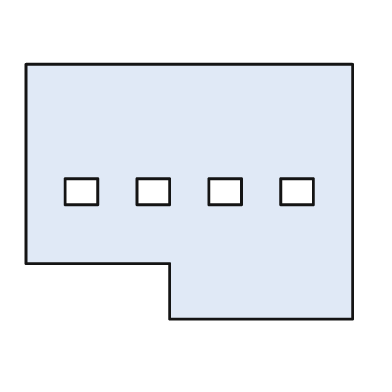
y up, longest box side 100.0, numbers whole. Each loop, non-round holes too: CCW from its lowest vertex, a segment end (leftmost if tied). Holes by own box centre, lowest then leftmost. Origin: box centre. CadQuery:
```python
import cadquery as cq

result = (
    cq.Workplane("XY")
    .moveTo(-6.0, -39.0)
    .lineTo(50.0, -39.0)
    .lineTo(50.0, 39.0)
    .lineTo(-50.0, 39.0)
    .lineTo(-50.0, -22.0)
    .lineTo(-6.0, -22.0)
    .close()
    .moveTo(-38.0, -4.0)
    .lineTo(-28.0, -4.0)
    .lineTo(-28.0, 4.0)
    .lineTo(-38.0, 4.0)
    .close()
    .moveTo(-16.0, -4.0)
    .lineTo(-6.0, -4.0)
    .lineTo(-6.0, 4.0)
    .lineTo(-16.0, 4.0)
    .close()
    .moveTo(6.0, -4.0)
    .lineTo(16.0, -4.0)
    .lineTo(16.0, 4.0)
    .lineTo(6.0, 4.0)
    .close()
    .moveTo(28.0, -4.0)
    .lineTo(38.0, -4.0)
    .lineTo(38.0, 4.0)
    .lineTo(28.0, 4.0)
    .close()
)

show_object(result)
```